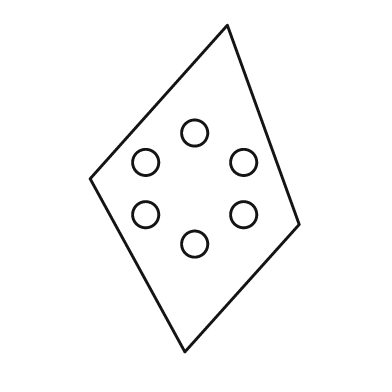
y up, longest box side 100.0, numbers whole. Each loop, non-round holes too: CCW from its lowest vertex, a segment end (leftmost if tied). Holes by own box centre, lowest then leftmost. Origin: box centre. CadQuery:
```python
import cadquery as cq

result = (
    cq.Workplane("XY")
    .moveTo(-3.0, -50.0)
    .lineTo(32.0, -11.0)
    .lineTo(10.0, 50.0)
    .lineTo(-32.0, 3.0)
    .close()
    .moveTo(0.0, -17.0)
    .circle(4.0)
    .moveTo(-15.0, -8.0)
    .circle(4.0)
    .moveTo(15.0, -8.0)
    .circle(4.0)
    .moveTo(-15.0, 8.0)
    .circle(4.0)
    .moveTo(15.0, 8.0)
    .circle(4.0)
    .moveTo(0.0, 17.0)
    .circle(4.0)
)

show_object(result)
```